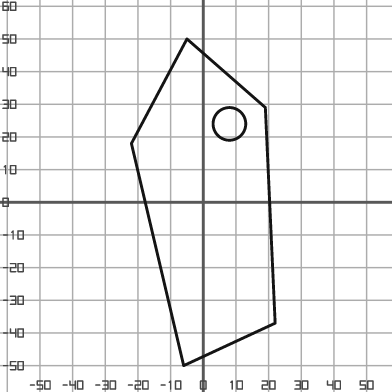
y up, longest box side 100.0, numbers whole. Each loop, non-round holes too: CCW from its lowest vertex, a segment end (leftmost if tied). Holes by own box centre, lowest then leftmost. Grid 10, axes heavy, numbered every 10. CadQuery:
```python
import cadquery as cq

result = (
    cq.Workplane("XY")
    .moveTo(-6.0, -50.0)
    .lineTo(22.0, -37.0)
    .lineTo(19.0, 29.0)
    .lineTo(-5.0, 50.0)
    .lineTo(-22.0, 18.0)
    .close()
    .moveTo(8.0, 24.0)
    .circle(5.0)
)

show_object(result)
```